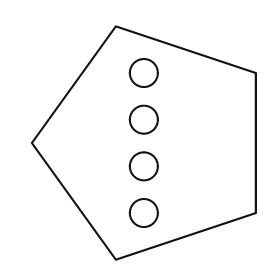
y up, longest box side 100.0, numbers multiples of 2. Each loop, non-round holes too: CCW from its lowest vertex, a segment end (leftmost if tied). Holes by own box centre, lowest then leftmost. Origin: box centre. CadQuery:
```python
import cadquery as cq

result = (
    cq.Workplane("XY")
    .moveTo(-12.0, -50.0)
    .lineTo(48.0, -30.0)
    .lineTo(48.0, 30.0)
    .lineTo(-12.0, 50.0)
    .lineTo(-48.0, 0.0)
    .close()
    .moveTo(0.0, -30.0)
    .circle(6.0)
    .moveTo(0.0, -10.0)
    .circle(6.0)
    .moveTo(0.0, 10.0)
    .circle(6.0)
    .moveTo(0.0, 30.0)
    .circle(6.0)
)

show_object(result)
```